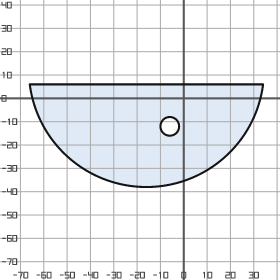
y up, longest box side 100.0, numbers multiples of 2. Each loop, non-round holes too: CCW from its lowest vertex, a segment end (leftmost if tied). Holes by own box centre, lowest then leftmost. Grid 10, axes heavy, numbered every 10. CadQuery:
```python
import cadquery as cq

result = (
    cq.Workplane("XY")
    .moveTo(-66.0, 6.0)
    .threePointArc((-16.0, -38.0), (34.0, 6.0))
    .close()
    .moveTo(-6.0, -12.0)
    .circle(4.0)
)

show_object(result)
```